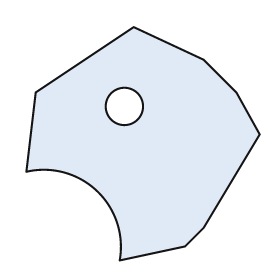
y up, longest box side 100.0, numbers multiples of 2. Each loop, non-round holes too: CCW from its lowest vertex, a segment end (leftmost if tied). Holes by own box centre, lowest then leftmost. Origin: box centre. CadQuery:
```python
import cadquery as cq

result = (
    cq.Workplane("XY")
    .moveTo(-10.0, -50.0)
    .lineTo(18.0, -44.0)
    .lineTo(26.0, -36.0)
    .lineTo(50.0, 4.0)
    .lineTo(40.0, 22.0)
    .lineTo(26.0, 36.0)
    .lineTo(-4.0, 50.0)
    .lineTo(-46.0, 22.0)
    .lineTo(-50.0, -12.0)
    .threePointArc((-20.0, -20.0), (-10.0, -50.0))
    .close()
    .moveTo(-8.0, 16.0)
    .circle(8.0)
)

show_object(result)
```